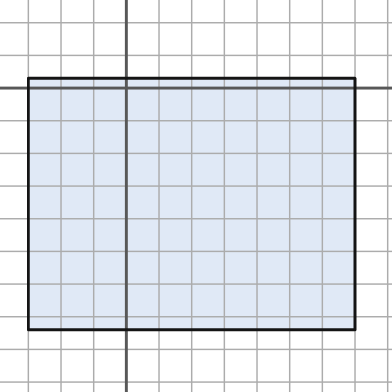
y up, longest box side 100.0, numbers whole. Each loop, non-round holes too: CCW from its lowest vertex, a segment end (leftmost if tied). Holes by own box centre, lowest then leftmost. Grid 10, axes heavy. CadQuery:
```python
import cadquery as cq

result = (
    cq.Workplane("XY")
    .moveTo(-30.0, -74.0)
    .lineTo(70.0, -74.0)
    .lineTo(70.0, 3.0)
    .lineTo(-30.0, 3.0)
    .close()
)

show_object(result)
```